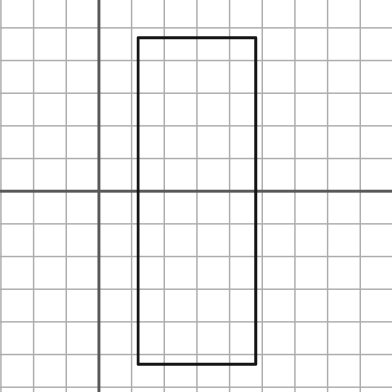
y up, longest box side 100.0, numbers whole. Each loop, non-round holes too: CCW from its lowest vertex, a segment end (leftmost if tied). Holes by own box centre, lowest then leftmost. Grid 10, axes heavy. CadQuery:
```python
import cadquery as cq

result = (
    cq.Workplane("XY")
    .moveTo(12.0, -53.0)
    .lineTo(48.0, -53.0)
    .lineTo(48.0, 47.0)
    .lineTo(12.0, 47.0)
    .close()
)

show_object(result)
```